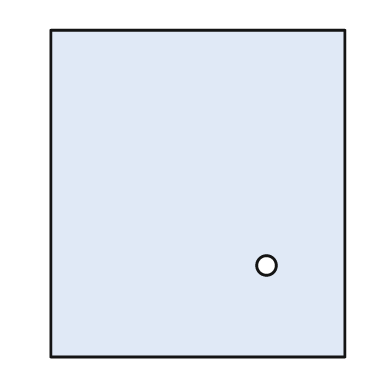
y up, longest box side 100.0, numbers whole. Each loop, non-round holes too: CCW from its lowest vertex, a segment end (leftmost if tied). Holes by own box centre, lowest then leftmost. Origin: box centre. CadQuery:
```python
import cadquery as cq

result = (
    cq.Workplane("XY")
    .moveTo(-45.0, -50.0)
    .lineTo(45.0, -50.0)
    .lineTo(45.0, 50.0)
    .lineTo(-45.0, 50.0)
    .close()
    .moveTo(21.0, -22.0)
    .circle(3.0)
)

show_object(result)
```